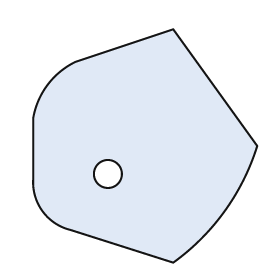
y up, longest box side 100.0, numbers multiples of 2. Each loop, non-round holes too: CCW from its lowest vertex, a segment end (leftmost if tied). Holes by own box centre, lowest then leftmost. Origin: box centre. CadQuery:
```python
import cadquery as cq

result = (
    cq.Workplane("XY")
    .moveTo(12.0, -50.0)
    .threePointArc((34.0, -28.0), (48.0, 0.0))
    .lineTo(12.0, 50.0)
    .lineTo(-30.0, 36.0)
    .threePointArc((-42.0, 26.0), (-48.0, 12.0))
    .lineTo(-48.0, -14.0)
    .threePointArc((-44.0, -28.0), (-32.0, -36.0))
    .close()
    .moveTo(-16.0, -12.0)
    .circle(6.0)
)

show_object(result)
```